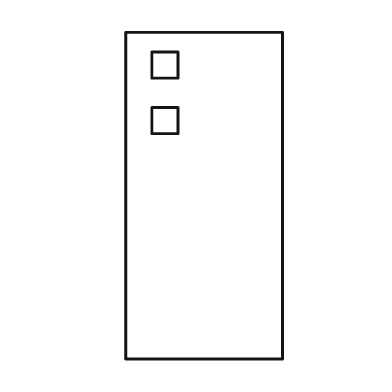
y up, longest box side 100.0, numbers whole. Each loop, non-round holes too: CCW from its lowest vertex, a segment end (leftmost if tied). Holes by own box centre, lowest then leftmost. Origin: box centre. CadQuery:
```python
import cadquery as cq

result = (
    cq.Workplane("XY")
    .moveTo(-24.0, -50.0)
    .lineTo(24.0, -50.0)
    .lineTo(24.0, 50.0)
    .lineTo(-24.0, 50.0)
    .close()
    .moveTo(-16.0, 19.0)
    .lineTo(-8.0, 19.0)
    .lineTo(-8.0, 27.0)
    .lineTo(-16.0, 27.0)
    .close()
    .moveTo(-16.0, 36.0)
    .lineTo(-8.0, 36.0)
    .lineTo(-8.0, 44.0)
    .lineTo(-16.0, 44.0)
    .close()
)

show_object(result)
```